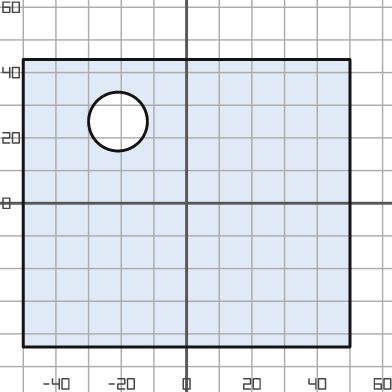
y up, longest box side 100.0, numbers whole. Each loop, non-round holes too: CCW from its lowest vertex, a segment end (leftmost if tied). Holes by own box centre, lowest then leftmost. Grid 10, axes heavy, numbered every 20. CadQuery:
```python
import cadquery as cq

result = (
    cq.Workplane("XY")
    .moveTo(-50.0, -44.0)
    .lineTo(50.0, -44.0)
    .lineTo(50.0, 44.0)
    .lineTo(-50.0, 44.0)
    .close()
    .moveTo(-21.0, 25.0)
    .circle(9.0)
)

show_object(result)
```